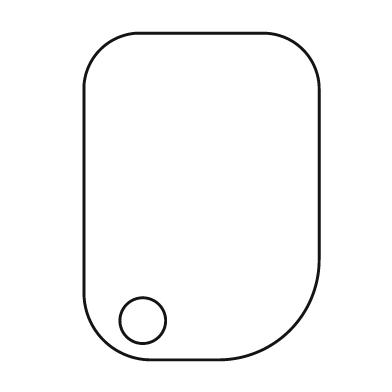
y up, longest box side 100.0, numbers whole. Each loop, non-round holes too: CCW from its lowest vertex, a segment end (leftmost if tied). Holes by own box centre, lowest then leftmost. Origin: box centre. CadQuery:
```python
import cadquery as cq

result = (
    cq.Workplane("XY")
    .moveTo(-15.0, -50.0)
    .lineTo(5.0, -50.0)
    .threePointArc((27.0, -41.0), (36.0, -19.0))
    .lineTo(36.0, 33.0)
    .threePointArc((31.0, 45.0), (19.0, 50.0))
    .lineTo(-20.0, 50.0)
    .threePointArc((-31.0, 45.0), (-36.0, 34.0))
    .lineTo(-36.0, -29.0)
    .threePointArc((-30.0, -44.0), (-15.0, -50.0))
    .close()
    .moveTo(-18.0, -38.0)
    .circle(7.0)
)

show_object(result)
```